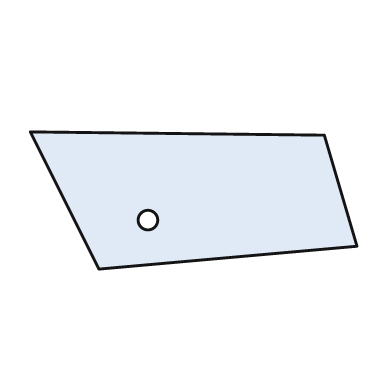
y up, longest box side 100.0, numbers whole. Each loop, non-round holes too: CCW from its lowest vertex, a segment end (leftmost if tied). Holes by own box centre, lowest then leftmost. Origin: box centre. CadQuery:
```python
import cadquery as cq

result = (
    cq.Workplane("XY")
    .moveTo(-29.0, -21.0)
    .lineTo(50.0, -14.0)
    .lineTo(40.0, 20.0)
    .lineTo(-50.0, 21.0)
    .close()
    .moveTo(-14.0, -6.0)
    .circle(3.0)
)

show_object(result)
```